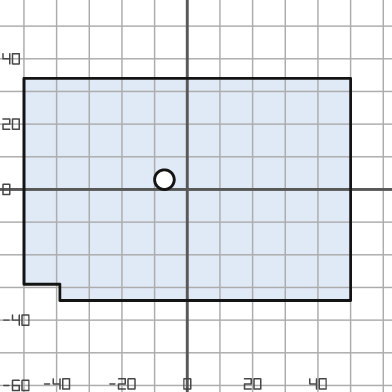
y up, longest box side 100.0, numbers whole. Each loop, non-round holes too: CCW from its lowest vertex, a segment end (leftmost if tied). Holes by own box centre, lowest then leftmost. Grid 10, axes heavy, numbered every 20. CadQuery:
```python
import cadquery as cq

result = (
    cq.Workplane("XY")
    .moveTo(-39.0, -34.0)
    .lineTo(50.0, -34.0)
    .lineTo(50.0, 34.0)
    .lineTo(-50.0, 34.0)
    .lineTo(-50.0, -29.0)
    .lineTo(-39.0, -29.0)
    .close()
    .moveTo(-7.0, 3.0)
    .circle(3.0)
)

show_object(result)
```